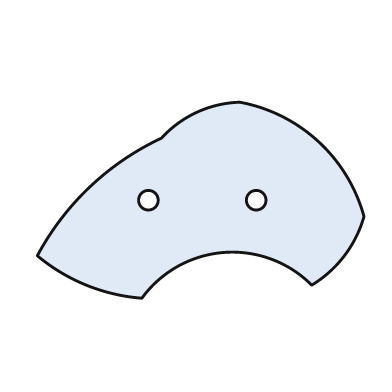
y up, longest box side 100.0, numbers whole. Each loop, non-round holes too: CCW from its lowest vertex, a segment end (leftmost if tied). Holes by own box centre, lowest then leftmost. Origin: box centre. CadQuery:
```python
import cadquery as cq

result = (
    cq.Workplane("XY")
    .moveTo(-18.0, -30.0)
    .threePointArc((7.0, -16.0), (34.0, -26.0))
    .threePointArc((44.0, -17.0), (50.0, -5.0))
    .threePointArc((36.0, 18.0), (12.0, 30.0))
    .threePointArc((-1.0, 27.0), (-12.0, 19.0))
    .threePointArc((-34.0, 4.0), (-50.0, -17.0))
    .threePointArc((-35.0, -26.0), (-18.0, -30.0))
    .close()
    .moveTo(-16.0, 0.0)
    .circle(3.0)
    .moveTo(17.0, 0.0)
    .circle(3.0)
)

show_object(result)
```